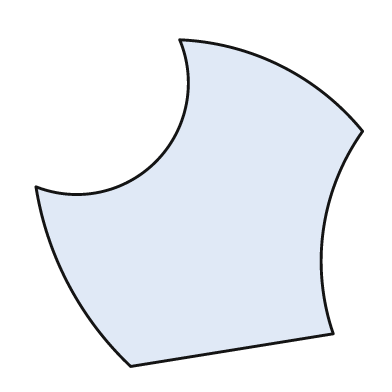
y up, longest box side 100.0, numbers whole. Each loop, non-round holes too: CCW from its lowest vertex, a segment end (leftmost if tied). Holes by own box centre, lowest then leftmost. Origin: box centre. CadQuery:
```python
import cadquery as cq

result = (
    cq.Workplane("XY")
    .moveTo(-21.0, -50.0)
    .lineTo(41.0, -40.0)
    .threePointArc((38.0, -8.0), (50.0, 22.0))
    .threePointArc((25.0, 42.0), (-6.0, 50.0))
    .threePointArc((-13.0, 13.0), (-50.0, 5.0))
    .threePointArc((-40.0, -25.0), (-21.0, -50.0))
    .close()
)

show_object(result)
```